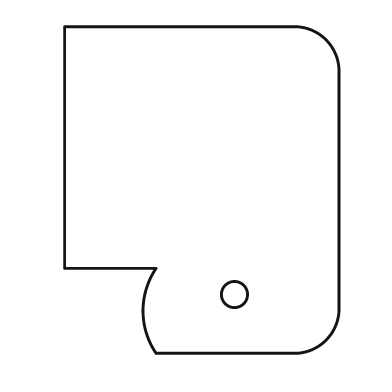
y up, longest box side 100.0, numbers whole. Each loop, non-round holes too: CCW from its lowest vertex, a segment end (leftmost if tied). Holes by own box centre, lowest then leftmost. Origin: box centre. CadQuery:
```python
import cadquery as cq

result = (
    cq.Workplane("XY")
    .moveTo(-14.0, -50.0)
    .lineTo(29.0, -50.0)
    .threePointArc((38.0, -46.0), (42.0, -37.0))
    .lineTo(42.0, 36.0)
    .threePointArc((38.0, 46.0), (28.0, 50.0))
    .lineTo(-42.0, 50.0)
    .lineTo(-42.0, -24.0)
    .lineTo(-14.0, -24.0)
    .threePointArc((-18.0, -37.0), (-14.0, -50.0))
    .close()
    .moveTo(10.0, -32.0)
    .circle(4.0)
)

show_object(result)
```